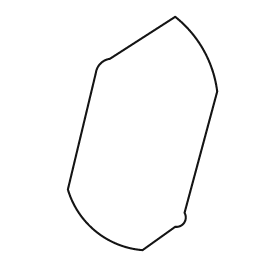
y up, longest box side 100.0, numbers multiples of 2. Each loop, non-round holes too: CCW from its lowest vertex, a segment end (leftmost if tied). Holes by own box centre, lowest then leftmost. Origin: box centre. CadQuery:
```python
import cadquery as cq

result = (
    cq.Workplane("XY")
    .moveTo(0.0, -50.0)
    .lineTo(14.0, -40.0)
    .threePointArc((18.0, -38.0), (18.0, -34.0))
    .lineTo(32.0, 18.0)
    .threePointArc((26.0, 36.0), (14.0, 50.0))
    .lineTo(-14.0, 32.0)
    .threePointArc((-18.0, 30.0), (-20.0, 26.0))
    .lineTo(-32.0, -24.0)
    .threePointArc((-20.0, -42.0), (0.0, -50.0))
    .close()
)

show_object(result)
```